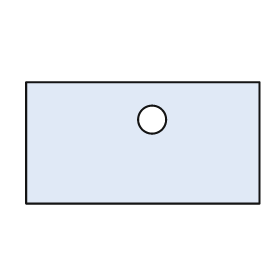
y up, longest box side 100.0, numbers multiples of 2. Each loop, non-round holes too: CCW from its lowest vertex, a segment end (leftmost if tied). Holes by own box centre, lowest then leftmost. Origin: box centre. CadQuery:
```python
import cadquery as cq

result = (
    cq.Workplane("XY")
    .moveTo(-50.0, -26.0)
    .lineTo(50.0, -26.0)
    .lineTo(50.0, 26.0)
    .lineTo(-50.0, 26.0)
    .close()
    .moveTo(4.0, 10.0)
    .circle(6.0)
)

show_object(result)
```